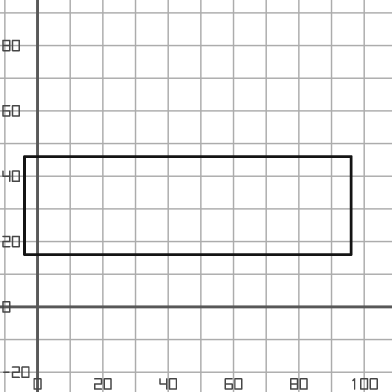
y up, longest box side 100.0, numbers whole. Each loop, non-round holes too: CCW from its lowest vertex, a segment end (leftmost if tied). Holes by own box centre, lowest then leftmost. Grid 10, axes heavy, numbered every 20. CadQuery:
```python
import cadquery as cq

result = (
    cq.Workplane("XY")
    .moveTo(-4.0, 16.0)
    .lineTo(96.0, 16.0)
    .lineTo(96.0, 46.0)
    .lineTo(-4.0, 46.0)
    .close()
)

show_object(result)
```